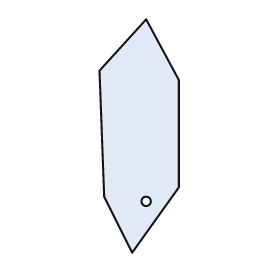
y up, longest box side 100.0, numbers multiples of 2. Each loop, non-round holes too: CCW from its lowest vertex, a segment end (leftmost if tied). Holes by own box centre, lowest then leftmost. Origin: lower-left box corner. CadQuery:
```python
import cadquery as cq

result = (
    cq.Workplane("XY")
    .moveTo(14.0, 0.0)
    .lineTo(34.0, 28.0)
    .lineTo(34.0, 74.0)
    .lineTo(20.0, 100.0)
    .lineTo(0.0, 78.0)
    .lineTo(2.0, 24.0)
    .close()
    .moveTo(20.0, 22.0)
    .circle(2.0)
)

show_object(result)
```